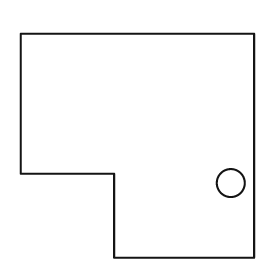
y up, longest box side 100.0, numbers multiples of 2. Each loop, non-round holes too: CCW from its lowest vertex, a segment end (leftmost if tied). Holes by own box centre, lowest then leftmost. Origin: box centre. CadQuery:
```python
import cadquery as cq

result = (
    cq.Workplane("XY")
    .moveTo(-10.0, -48.0)
    .lineTo(50.0, -48.0)
    .lineTo(50.0, 48.0)
    .lineTo(-50.0, 48.0)
    .lineTo(-50.0, -12.0)
    .lineTo(-10.0, -12.0)
    .close()
    .moveTo(40.0, -16.0)
    .circle(6.0)
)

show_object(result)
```